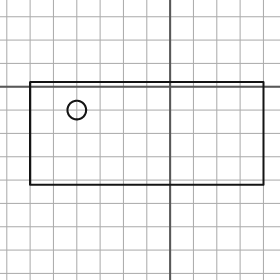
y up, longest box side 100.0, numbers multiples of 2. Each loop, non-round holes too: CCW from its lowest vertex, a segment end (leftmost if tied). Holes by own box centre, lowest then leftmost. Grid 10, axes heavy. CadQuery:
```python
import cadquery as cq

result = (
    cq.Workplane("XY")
    .moveTo(-60.0, -42.0)
    .lineTo(40.0, -42.0)
    .lineTo(40.0, 2.0)
    .lineTo(-60.0, 2.0)
    .close()
    .moveTo(-40.0, -10.0)
    .circle(4.0)
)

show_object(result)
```